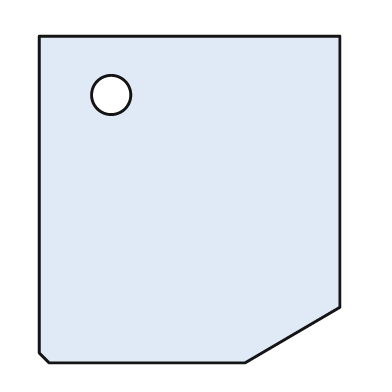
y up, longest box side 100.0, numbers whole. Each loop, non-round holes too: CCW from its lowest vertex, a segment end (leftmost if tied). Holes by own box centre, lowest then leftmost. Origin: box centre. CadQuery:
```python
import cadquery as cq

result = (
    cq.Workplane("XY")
    .moveTo(-43.0, -50.0)
    .lineTo(17.0, -50.0)
    .lineTo(46.0, -33.0)
    .lineTo(46.0, 50.0)
    .lineTo(-46.0, 50.0)
    .lineTo(-46.0, -47.0)
    .close()
    .moveTo(-24.0, 32.0)
    .circle(6.0)
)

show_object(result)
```